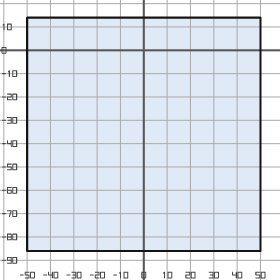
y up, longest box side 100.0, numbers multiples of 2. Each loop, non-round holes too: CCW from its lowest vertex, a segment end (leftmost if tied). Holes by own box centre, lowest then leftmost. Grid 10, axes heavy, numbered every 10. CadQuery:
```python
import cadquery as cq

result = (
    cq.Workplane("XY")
    .moveTo(-50.0, -86.0)
    .lineTo(50.0, -86.0)
    .lineTo(50.0, 14.0)
    .lineTo(-50.0, 14.0)
    .close()
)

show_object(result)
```